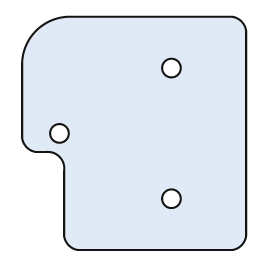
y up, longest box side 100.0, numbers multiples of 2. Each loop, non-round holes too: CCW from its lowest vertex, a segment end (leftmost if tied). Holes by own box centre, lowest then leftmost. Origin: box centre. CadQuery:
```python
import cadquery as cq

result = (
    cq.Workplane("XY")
    .moveTo(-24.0, -50.0)
    .lineTo(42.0, -50.0)
    .threePointArc((46.0, -48.0), (48.0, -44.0))
    .lineTo(48.0, 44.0)
    .threePointArc((46.0, 48.0), (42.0, 50.0))
    .lineTo(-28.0, 50.0)
    .threePointArc((-42.0, 44.0), (-48.0, 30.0))
    .lineTo(-48.0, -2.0)
    .threePointArc((-46.0, -6.0), (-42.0, -8.0))
    .lineTo(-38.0, -8.0)
    .threePointArc((-32.0, -10.0), (-30.0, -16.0))
    .lineTo(-30.0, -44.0)
    .threePointArc((-28.0, -48.0), (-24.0, -50.0))
    .close()
    .moveTo(16.0, -28.0)
    .circle(4.0)
    .moveTo(-32.0, 0.0)
    .circle(4.0)
    .moveTo(16.0, 28.0)
    .circle(4.0)
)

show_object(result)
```